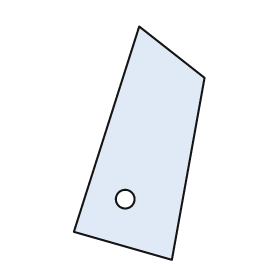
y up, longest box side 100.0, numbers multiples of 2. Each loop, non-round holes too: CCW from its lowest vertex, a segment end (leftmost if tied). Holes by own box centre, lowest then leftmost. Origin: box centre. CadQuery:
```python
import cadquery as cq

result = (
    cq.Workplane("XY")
    .moveTo(14.0, -50.0)
    .lineTo(28.0, 28.0)
    .lineTo(0.0, 50.0)
    .lineTo(-28.0, -38.0)
    .close()
    .moveTo(-6.0, -24.0)
    .circle(4.0)
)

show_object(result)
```